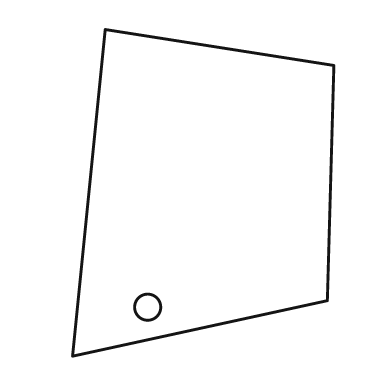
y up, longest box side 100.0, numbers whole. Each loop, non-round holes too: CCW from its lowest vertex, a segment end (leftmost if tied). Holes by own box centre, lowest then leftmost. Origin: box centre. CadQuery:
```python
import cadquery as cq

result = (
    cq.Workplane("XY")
    .moveTo(-40.0, -50.0)
    .lineTo(38.0, -33.0)
    .lineTo(40.0, 39.0)
    .lineTo(-30.0, 50.0)
    .close()
    .moveTo(-17.0, -35.0)
    .circle(4.0)
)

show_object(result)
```